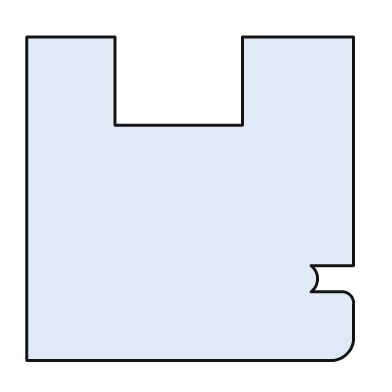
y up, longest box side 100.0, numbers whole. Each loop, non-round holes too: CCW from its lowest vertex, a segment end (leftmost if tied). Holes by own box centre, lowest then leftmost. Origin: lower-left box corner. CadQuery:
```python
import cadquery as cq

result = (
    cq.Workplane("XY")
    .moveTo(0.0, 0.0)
    .lineTo(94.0, 0.0)
    .threePointArc((98.0, 2.0), (100.0, 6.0))
    .lineTo(100.0, 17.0)
    .threePointArc((99.0, 20.0), (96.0, 21.0))
    .lineTo(87.0, 21.0)
    .threePointArc((89.0, 25.0), (87.0, 29.0))
    .lineTo(100.0, 29.0)
    .lineTo(100.0, 99.0)
    .lineTo(66.0, 99.0)
    .lineTo(66.0, 72.0)
    .lineTo(27.0, 72.0)
    .lineTo(27.0, 99.0)
    .lineTo(0.0, 99.0)
    .close()
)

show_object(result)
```